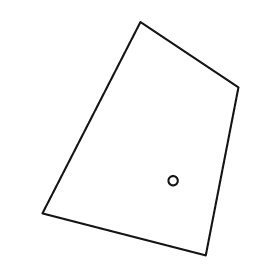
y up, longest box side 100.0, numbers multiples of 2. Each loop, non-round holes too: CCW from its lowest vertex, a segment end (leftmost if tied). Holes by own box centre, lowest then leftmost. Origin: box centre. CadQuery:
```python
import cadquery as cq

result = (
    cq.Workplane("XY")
    .moveTo(28.0, -50.0)
    .lineTo(42.0, 22.0)
    .lineTo(0.0, 50.0)
    .lineTo(-42.0, -32.0)
    .close()
    .moveTo(14.0, -18.0)
    .circle(2.0)
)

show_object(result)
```